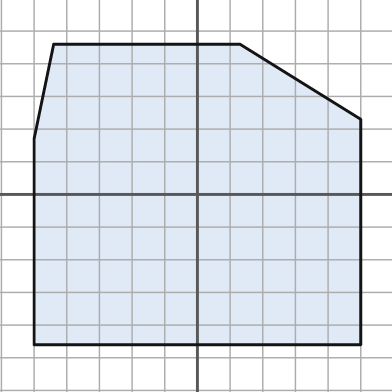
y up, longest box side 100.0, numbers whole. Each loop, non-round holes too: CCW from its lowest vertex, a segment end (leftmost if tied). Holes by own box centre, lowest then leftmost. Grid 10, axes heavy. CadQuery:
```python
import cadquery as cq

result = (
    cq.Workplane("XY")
    .moveTo(-50.0, -46.0)
    .lineTo(50.0, -46.0)
    .lineTo(50.0, 23.0)
    .lineTo(13.0, 46.0)
    .lineTo(-44.0, 46.0)
    .lineTo(-50.0, 17.0)
    .close()
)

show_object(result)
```